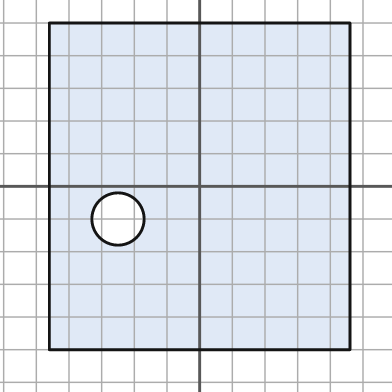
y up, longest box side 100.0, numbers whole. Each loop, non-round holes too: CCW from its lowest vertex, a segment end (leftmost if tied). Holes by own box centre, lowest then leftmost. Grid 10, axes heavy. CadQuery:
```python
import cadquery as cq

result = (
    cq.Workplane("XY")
    .moveTo(-46.0, -50.0)
    .lineTo(46.0, -50.0)
    .lineTo(46.0, 50.0)
    .lineTo(-46.0, 50.0)
    .close()
    .moveTo(-25.0, -10.0)
    .circle(8.0)
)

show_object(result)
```